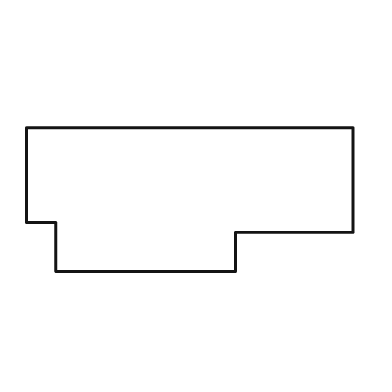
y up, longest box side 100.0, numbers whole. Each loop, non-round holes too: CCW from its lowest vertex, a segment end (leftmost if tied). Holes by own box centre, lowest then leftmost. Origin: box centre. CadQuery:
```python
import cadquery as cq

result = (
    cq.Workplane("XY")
    .moveTo(-41.0, -22.0)
    .lineTo(14.0, -22.0)
    .lineTo(14.0, -10.0)
    .lineTo(50.0, -10.0)
    .lineTo(50.0, 22.0)
    .lineTo(-50.0, 22.0)
    .lineTo(-50.0, -7.0)
    .lineTo(-41.0, -7.0)
    .close()
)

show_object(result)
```